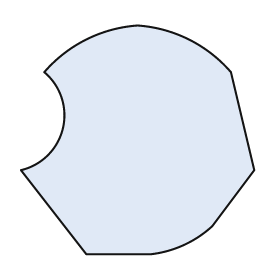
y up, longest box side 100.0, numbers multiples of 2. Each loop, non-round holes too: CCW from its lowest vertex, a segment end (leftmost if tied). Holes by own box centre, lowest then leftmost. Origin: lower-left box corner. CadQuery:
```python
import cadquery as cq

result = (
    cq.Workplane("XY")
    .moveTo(28.0, 0.0)
    .lineTo(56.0, 0.0)
    .threePointArc((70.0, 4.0), (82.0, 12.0))
    .lineTo(100.0, 36.0)
    .lineTo(90.0, 78.0)
    .threePointArc((72.0, 92.0), (50.0, 98.0))
    .threePointArc((28.0, 92.0), (10.0, 78.0))
    .threePointArc((18.0, 54.0), (0.0, 36.0))
    .close()
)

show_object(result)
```